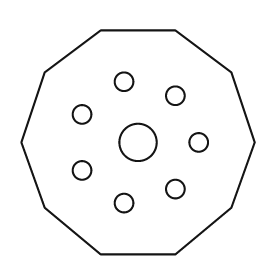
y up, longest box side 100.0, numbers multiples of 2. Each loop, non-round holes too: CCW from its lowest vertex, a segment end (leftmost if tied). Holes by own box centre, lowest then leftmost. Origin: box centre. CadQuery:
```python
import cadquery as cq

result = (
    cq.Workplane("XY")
    .moveTo(-16.0, -48.0)
    .lineTo(16.0, -48.0)
    .lineTo(40.0, -28.0)
    .lineTo(50.0, 0.0)
    .lineTo(40.0, 30.0)
    .lineTo(16.0, 48.0)
    .lineTo(-16.0, 48.0)
    .lineTo(-40.0, 30.0)
    .lineTo(-50.0, 0.0)
    .lineTo(-40.0, -28.0)
    .close()
    .moveTo(-6.0, -26.0)
    .circle(4.0)
    .moveTo(16.0, -20.0)
    .circle(4.0)
    .moveTo(-24.0, -12.0)
    .circle(4.0)
    .moveTo(0.0, 0.0)
    .circle(8.0)
    .moveTo(26.0, 0.0)
    .circle(4.0)
    .moveTo(-24.0, 12.0)
    .circle(4.0)
    .moveTo(16.0, 20.0)
    .circle(4.0)
    .moveTo(-6.0, 26.0)
    .circle(4.0)
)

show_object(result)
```